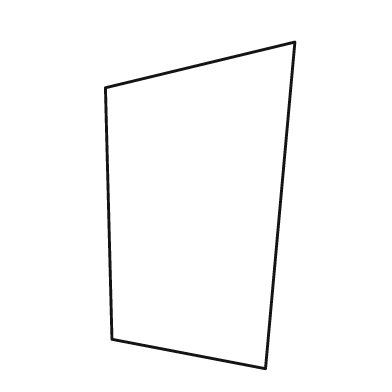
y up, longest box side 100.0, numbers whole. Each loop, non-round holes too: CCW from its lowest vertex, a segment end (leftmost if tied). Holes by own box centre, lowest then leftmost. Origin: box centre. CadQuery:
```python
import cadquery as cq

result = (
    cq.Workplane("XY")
    .moveTo(20.0, -50.0)
    .lineTo(29.0, 50.0)
    .lineTo(-29.0, 36.0)
    .lineTo(-27.0, -41.0)
    .close()
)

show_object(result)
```